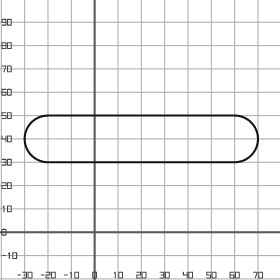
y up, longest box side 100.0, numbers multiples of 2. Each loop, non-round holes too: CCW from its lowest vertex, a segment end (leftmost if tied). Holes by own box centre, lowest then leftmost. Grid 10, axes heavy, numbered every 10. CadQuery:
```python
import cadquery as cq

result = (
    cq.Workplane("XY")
    .moveTo(-20.0, 30.0)
    .lineTo(60.0, 30.0)
    .threePointArc((70.0, 40.0), (60.0, 50.0))
    .lineTo(-20.0, 50.0)
    .threePointArc((-30.0, 40.0), (-20.0, 30.0))
    .close()
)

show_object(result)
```